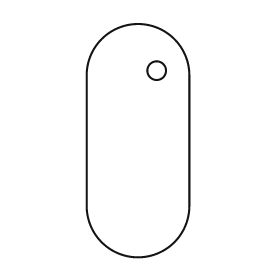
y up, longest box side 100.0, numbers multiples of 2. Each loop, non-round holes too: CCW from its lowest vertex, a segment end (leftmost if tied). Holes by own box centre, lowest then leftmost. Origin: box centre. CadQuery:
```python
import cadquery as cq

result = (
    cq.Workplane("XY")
    .moveTo(-22.0, -28.0)
    .threePointArc((0.0, -50.0), (22.0, -28.0))
    .lineTo(22.0, 28.0)
    .threePointArc((0.0, 50.0), (-22.0, 28.0))
    .close()
    .moveTo(8.0, 30.0)
    .circle(4.0)
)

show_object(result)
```